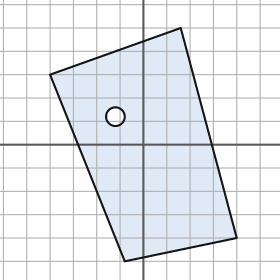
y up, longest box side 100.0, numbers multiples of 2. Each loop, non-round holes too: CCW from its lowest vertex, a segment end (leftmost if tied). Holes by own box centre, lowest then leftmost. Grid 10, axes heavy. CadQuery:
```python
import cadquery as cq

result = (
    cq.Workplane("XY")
    .moveTo(-8.0, -50.0)
    .lineTo(40.0, -40.0)
    .lineTo(16.0, 50.0)
    .lineTo(-40.0, 30.0)
    .close()
    .moveTo(-12.0, 12.0)
    .circle(4.0)
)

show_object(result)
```